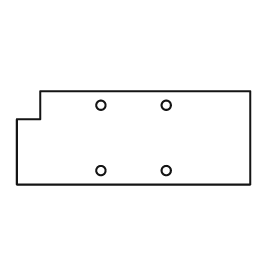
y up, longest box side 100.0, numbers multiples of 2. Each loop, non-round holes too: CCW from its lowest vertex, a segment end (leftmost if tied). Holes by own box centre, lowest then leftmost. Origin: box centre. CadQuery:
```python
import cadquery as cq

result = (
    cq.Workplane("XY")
    .moveTo(-50.0, -20.0)
    .lineTo(50.0, -20.0)
    .lineTo(50.0, 20.0)
    .lineTo(-40.0, 20.0)
    .lineTo(-40.0, 8.0)
    .lineTo(-50.0, 8.0)
    .close()
    .moveTo(-14.0, -14.0)
    .circle(2.0)
    .moveTo(14.0, -14.0)
    .circle(2.0)
    .moveTo(-14.0, 14.0)
    .circle(2.0)
    .moveTo(14.0, 14.0)
    .circle(2.0)
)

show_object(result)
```